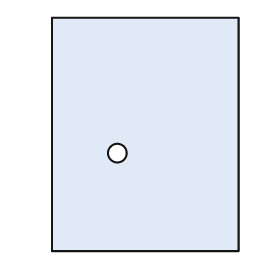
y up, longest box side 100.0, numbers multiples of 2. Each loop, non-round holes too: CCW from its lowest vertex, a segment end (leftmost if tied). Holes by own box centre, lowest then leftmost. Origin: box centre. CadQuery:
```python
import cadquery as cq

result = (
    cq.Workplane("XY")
    .moveTo(-40.0, -50.0)
    .lineTo(40.0, -50.0)
    .lineTo(40.0, 50.0)
    .lineTo(-40.0, 50.0)
    .close()
    .moveTo(-12.0, -8.0)
    .circle(4.0)
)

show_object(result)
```